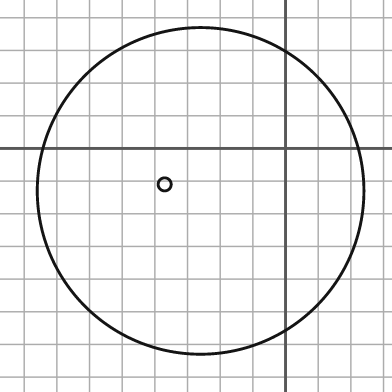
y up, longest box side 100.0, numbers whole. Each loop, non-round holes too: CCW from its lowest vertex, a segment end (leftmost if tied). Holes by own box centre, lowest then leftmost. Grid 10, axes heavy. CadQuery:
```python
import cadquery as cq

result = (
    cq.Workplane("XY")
    .moveTo(-26.0, -13.0)
    .circle(50.0)
    .moveTo(-37.0, -11.0)
    .circle(2.0)
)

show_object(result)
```